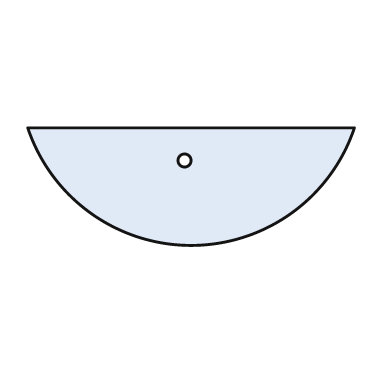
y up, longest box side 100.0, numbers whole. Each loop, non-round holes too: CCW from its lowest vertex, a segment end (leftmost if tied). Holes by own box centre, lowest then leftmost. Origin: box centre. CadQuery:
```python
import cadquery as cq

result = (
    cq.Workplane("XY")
    .moveTo(-50.0, 18.0)
    .threePointArc((0.0, -18.0), (50.0, 18.0))
    .close()
    .moveTo(-2.0, 8.0)
    .circle(2.0)
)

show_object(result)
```